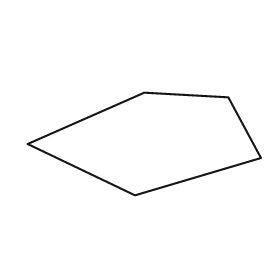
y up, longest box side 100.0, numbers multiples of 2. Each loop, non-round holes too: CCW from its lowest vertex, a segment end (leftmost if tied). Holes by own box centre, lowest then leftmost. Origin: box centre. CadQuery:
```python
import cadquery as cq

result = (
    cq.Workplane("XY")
    .moveTo(-4.0, -22.0)
    .lineTo(50.0, -6.0)
    .lineTo(36.0, 20.0)
    .lineTo(0.0, 22.0)
    .lineTo(-50.0, 0.0)
    .close()
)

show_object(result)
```